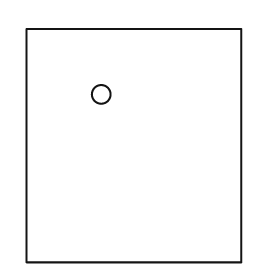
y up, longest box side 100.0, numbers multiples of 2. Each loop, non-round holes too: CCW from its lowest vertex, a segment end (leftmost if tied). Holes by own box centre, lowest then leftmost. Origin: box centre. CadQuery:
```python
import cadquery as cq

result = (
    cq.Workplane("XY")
    .moveTo(-46.0, -50.0)
    .lineTo(46.0, -50.0)
    .lineTo(46.0, 50.0)
    .lineTo(-46.0, 50.0)
    .close()
    .moveTo(-14.0, 22.0)
    .circle(4.0)
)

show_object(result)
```